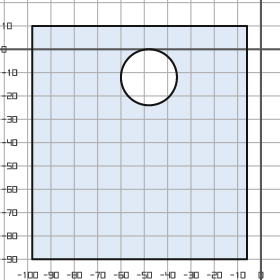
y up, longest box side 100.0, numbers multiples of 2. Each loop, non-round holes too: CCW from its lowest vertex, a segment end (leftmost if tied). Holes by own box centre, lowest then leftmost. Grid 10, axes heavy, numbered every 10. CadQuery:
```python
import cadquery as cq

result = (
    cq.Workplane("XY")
    .moveTo(-98.0, -90.0)
    .lineTo(-6.0, -90.0)
    .lineTo(-6.0, 10.0)
    .lineTo(-98.0, 10.0)
    .close()
    .moveTo(-48.0, -12.0)
    .circle(12.0)
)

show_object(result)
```